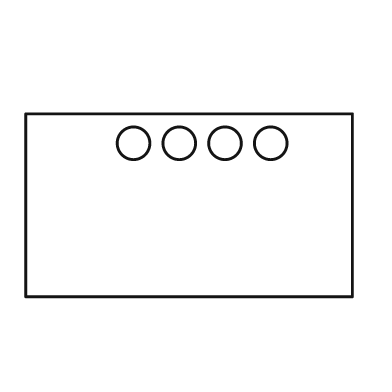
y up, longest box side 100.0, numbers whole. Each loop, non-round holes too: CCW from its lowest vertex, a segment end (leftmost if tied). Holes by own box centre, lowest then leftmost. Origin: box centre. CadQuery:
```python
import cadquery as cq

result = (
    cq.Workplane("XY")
    .moveTo(-50.0, -28.0)
    .lineTo(50.0, -28.0)
    .lineTo(50.0, 28.0)
    .lineTo(-50.0, 28.0)
    .close()
    .moveTo(-17.0, 19.0)
    .circle(5.0)
    .moveTo(-3.0, 19.0)
    .circle(5.0)
    .moveTo(11.0, 19.0)
    .circle(5.0)
    .moveTo(25.0, 19.0)
    .circle(5.0)
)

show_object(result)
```